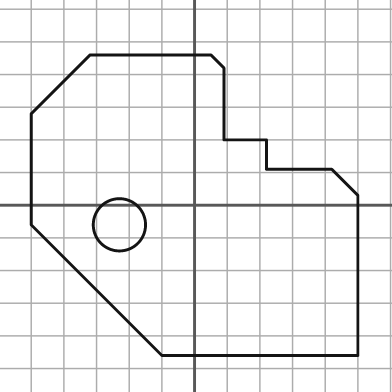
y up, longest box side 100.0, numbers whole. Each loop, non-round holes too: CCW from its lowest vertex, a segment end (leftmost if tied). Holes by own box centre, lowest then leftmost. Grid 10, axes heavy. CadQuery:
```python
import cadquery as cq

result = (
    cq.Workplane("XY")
    .moveTo(-10.0, -46.0)
    .lineTo(50.0, -46.0)
    .lineTo(50.0, 3.0)
    .lineTo(42.0, 11.0)
    .lineTo(22.0, 11.0)
    .lineTo(22.0, 20.0)
    .lineTo(9.0, 20.0)
    .lineTo(9.0, 42.0)
    .lineTo(5.0, 46.0)
    .lineTo(-32.0, 46.0)
    .lineTo(-50.0, 28.0)
    .lineTo(-50.0, -6.0)
    .close()
    .moveTo(-23.0, -6.0)
    .circle(8.0)
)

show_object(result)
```